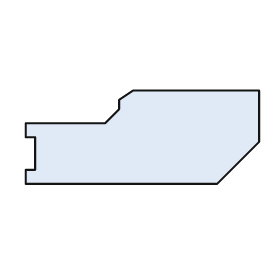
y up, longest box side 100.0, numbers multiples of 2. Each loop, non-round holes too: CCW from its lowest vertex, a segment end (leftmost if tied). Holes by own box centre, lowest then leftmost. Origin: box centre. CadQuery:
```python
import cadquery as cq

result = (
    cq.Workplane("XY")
    .moveTo(-50.0, -20.0)
    .lineTo(32.0, -20.0)
    .lineTo(50.0, -2.0)
    .lineTo(50.0, 20.0)
    .lineTo(-4.0, 20.0)
    .lineTo(-10.0, 16.0)
    .lineTo(-10.0, 12.0)
    .lineTo(-16.0, 6.0)
    .lineTo(-50.0, 6.0)
    .lineTo(-50.0, 0.0)
    .lineTo(-46.0, 0.0)
    .lineTo(-46.0, -14.0)
    .lineTo(-50.0, -14.0)
    .close()
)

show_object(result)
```